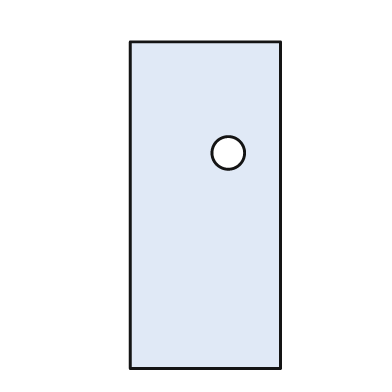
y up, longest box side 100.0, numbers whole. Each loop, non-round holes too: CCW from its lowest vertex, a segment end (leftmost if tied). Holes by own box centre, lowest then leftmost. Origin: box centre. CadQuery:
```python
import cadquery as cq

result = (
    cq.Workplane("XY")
    .moveTo(-23.0, -50.0)
    .lineTo(23.0, -50.0)
    .lineTo(23.0, 50.0)
    .lineTo(-23.0, 50.0)
    .close()
    .moveTo(7.0, 16.0)
    .circle(5.0)
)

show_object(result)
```